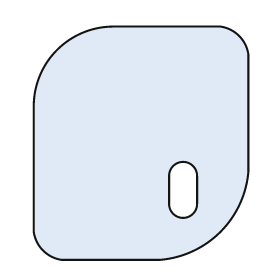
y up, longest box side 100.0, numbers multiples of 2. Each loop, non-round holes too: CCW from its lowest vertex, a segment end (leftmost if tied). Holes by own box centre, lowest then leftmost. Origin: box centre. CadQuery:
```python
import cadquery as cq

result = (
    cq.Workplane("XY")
    .moveTo(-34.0, -50.0)
    .lineTo(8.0, -50.0)
    .threePointArc((34.0, -38.0), (46.0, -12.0))
    .lineTo(46.0, 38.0)
    .threePointArc((42.0, 46.0), (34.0, 50.0))
    .lineTo(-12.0, 50.0)
    .threePointArc((-36.0, 40.0), (-46.0, 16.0))
    .lineTo(-46.0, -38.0)
    .threePointArc((-42.0, -46.0), (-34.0, -50.0))
    .close()
    .moveTo(12.0, -26.0)
    .threePointArc((18.0, -32.0), (24.0, -26.0))
    .lineTo(24.0, -14.0)
    .threePointArc((18.0, -8.0), (12.0, -14.0))
    .close()
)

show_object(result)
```